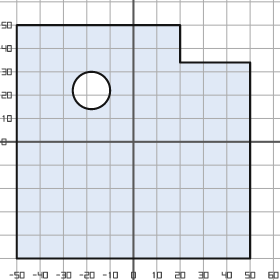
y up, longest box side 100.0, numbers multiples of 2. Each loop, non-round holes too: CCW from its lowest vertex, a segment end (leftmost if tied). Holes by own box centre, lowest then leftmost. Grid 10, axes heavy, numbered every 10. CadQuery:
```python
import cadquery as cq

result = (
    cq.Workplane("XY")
    .moveTo(-50.0, -50.0)
    .lineTo(50.0, -50.0)
    .lineTo(50.0, 34.0)
    .lineTo(20.0, 34.0)
    .lineTo(20.0, 50.0)
    .lineTo(-50.0, 50.0)
    .close()
    .moveTo(-18.0, 22.0)
    .circle(8.0)
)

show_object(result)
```